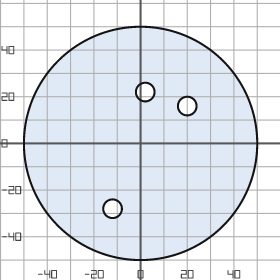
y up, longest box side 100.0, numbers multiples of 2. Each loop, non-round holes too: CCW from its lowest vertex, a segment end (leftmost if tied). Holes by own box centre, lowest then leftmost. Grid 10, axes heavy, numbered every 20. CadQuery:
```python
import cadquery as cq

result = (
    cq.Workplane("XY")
    .moveTo(0.0, 0.0)
    .circle(50.0)
    .moveTo(-12.0, -28.0)
    .circle(4.0)
    .moveTo(20.0, 16.0)
    .circle(4.0)
    .moveTo(2.0, 22.0)
    .circle(4.0)
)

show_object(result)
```